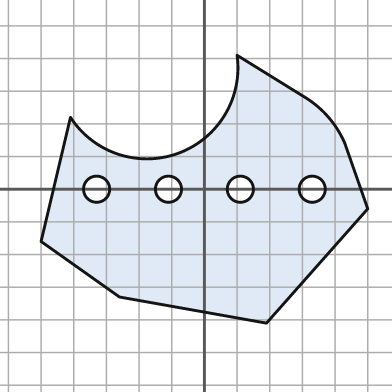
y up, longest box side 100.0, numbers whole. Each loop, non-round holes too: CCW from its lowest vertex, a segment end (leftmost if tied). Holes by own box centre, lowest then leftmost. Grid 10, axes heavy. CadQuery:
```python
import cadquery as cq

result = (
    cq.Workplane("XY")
    .moveTo(19.0, -41.0)
    .lineTo(50.0, -6.0)
    .lineTo(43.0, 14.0)
    .threePointArc((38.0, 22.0), (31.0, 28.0))
    .lineTo(10.0, 41.0)
    .threePointArc((-8.0, 11.0), (-41.0, 22.0))
    .lineTo(-50.0, -16.0)
    .lineTo(-26.0, -33.0)
    .close()
    .moveTo(-33.0, 0.0)
    .circle(4.0)
    .moveTo(-11.0, 0.0)
    .circle(4.0)
    .moveTo(11.0, 0.0)
    .circle(4.0)
    .moveTo(33.0, 0.0)
    .circle(4.0)
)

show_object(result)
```